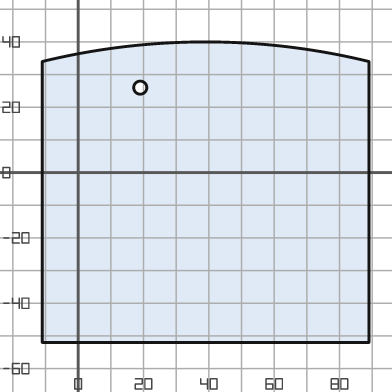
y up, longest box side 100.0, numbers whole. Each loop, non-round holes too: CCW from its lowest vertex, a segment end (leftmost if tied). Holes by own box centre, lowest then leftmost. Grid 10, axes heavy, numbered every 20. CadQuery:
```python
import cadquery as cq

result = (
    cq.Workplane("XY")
    .moveTo(-11.0, -52.0)
    .lineTo(89.0, -52.0)
    .lineTo(89.0, 34.0)
    .threePointArc((39.0, 40.0), (-11.0, 34.0))
    .close()
    .moveTo(19.0, 26.0)
    .circle(2.0)
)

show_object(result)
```